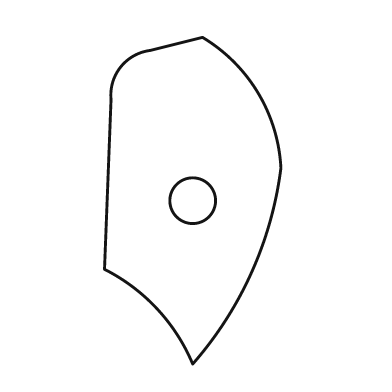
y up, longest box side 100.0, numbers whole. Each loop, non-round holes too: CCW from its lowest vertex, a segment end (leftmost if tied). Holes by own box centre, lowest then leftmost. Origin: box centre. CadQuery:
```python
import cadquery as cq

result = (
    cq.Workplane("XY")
    .moveTo(0.0, -50.0)
    .threePointArc((18.0, -22.0), (27.0, 10.0))
    .threePointArc((20.0, 33.0), (3.0, 50.0))
    .lineTo(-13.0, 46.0)
    .threePointArc((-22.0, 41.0), (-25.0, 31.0))
    .lineTo(-27.0, -21.0)
    .threePointArc((-11.0, -33.0), (0.0, -50.0))
    .close()
    .moveTo(0.0, 0.0)
    .circle(7.0)
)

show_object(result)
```